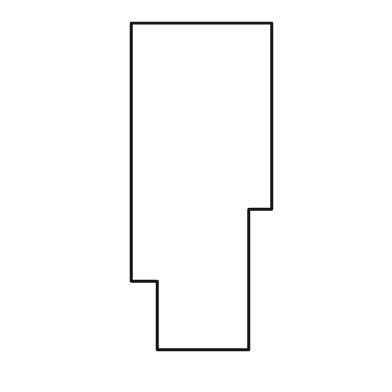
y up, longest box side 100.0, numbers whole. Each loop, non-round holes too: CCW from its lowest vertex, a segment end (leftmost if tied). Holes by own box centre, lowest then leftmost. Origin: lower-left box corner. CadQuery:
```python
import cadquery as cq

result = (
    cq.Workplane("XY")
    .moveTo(8.0, 0.0)
    .lineTo(36.0, 0.0)
    .lineTo(36.0, 43.0)
    .lineTo(43.0, 43.0)
    .lineTo(43.0, 100.0)
    .lineTo(0.0, 100.0)
    .lineTo(0.0, 21.0)
    .lineTo(8.0, 21.0)
    .close()
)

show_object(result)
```